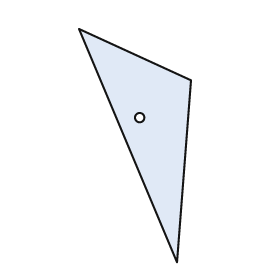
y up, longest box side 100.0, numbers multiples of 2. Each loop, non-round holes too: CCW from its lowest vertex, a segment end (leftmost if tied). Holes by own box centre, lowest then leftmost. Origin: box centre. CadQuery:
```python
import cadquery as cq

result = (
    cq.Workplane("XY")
    .moveTo(18.0, -50.0)
    .lineTo(24.0, 28.0)
    .lineTo(-24.0, 50.0)
    .close()
    .moveTo(2.0, 12.0)
    .circle(2.0)
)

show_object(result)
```